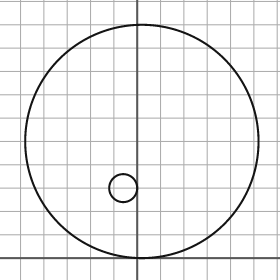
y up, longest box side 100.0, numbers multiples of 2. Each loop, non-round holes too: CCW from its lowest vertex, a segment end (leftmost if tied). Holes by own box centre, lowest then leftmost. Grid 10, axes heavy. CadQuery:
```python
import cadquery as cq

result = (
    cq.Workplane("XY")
    .moveTo(2.0, 50.0)
    .circle(50.0)
    .moveTo(-6.0, 30.0)
    .circle(6.0)
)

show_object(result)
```